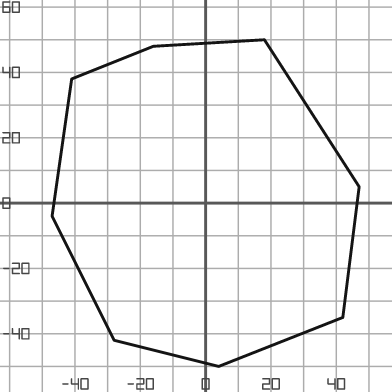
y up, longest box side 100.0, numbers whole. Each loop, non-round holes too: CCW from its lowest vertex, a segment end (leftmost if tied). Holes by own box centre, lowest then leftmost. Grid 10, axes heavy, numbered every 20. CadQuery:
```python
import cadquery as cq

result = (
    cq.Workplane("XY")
    .moveTo(4.0, -50.0)
    .lineTo(42.0, -35.0)
    .lineTo(47.0, 5.0)
    .lineTo(18.0, 50.0)
    .lineTo(-16.0, 48.0)
    .lineTo(-41.0, 38.0)
    .lineTo(-47.0, -4.0)
    .lineTo(-28.0, -42.0)
    .close()
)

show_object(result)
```